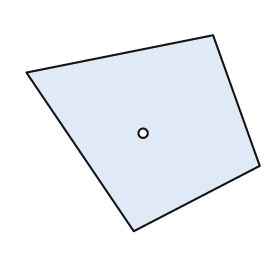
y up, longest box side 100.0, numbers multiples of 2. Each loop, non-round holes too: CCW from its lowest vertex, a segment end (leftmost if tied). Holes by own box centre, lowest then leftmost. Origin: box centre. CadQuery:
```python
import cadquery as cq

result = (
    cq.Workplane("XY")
    .moveTo(-4.0, -42.0)
    .lineTo(50.0, -14.0)
    .lineTo(30.0, 42.0)
    .lineTo(-50.0, 26.0)
    .close()
    .moveTo(0.0, 0.0)
    .circle(2.0)
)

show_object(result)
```